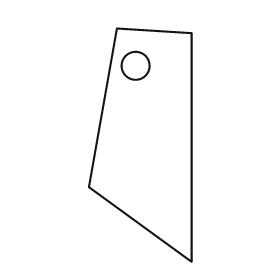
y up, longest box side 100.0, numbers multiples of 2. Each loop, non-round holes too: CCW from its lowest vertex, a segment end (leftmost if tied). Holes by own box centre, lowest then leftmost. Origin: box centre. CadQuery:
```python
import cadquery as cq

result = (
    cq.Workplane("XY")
    .moveTo(22.0, -50.0)
    .lineTo(22.0, 48.0)
    .lineTo(-10.0, 50.0)
    .lineTo(-22.0, -18.0)
    .close()
    .moveTo(-2.0, 34.0)
    .circle(6.0)
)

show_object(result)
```